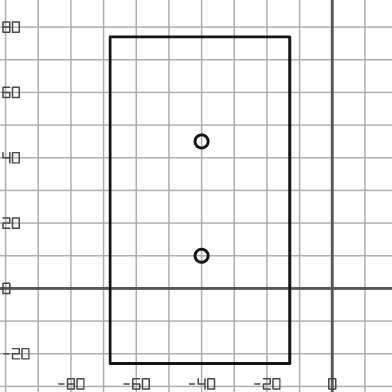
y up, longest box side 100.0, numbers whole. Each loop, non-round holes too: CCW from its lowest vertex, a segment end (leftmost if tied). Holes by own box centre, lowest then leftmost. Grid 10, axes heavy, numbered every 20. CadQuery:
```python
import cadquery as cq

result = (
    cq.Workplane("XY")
    .moveTo(-68.0, -23.0)
    .lineTo(-13.0, -23.0)
    .lineTo(-13.0, 77.0)
    .lineTo(-68.0, 77.0)
    .close()
    .moveTo(-40.0, 10.0)
    .circle(2.0)
    .moveTo(-40.0, 45.0)
    .circle(2.0)
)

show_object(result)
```